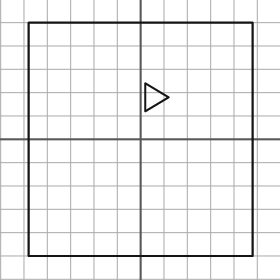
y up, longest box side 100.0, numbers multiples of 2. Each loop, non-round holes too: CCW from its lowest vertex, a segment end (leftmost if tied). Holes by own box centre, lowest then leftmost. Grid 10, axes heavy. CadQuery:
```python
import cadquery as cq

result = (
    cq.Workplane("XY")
    .moveTo(-48.0, -50.0)
    .lineTo(48.0, -50.0)
    .lineTo(48.0, 50.0)
    .lineTo(-48.0, 50.0)
    .close()
    .moveTo(2.0, 12.0)
    .lineTo(12.0, 18.0)
    .lineTo(2.0, 24.0)
    .close()
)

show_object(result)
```